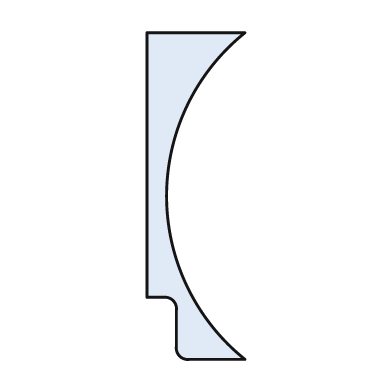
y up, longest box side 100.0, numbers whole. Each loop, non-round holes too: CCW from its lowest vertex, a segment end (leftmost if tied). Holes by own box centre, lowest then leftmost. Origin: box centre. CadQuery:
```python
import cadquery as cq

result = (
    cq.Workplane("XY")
    .moveTo(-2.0, -50.0)
    .lineTo(15.0, -50.0)
    .threePointArc((-9.0, 0.0), (15.0, 50.0))
    .lineTo(-15.0, 50.0)
    .lineTo(-15.0, -31.0)
    .lineTo(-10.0, -31.0)
    .threePointArc((-7.0, -32.0), (-6.0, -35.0))
    .lineTo(-6.0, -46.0)
    .threePointArc((-5.0, -49.0), (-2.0, -50.0))
    .close()
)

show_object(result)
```